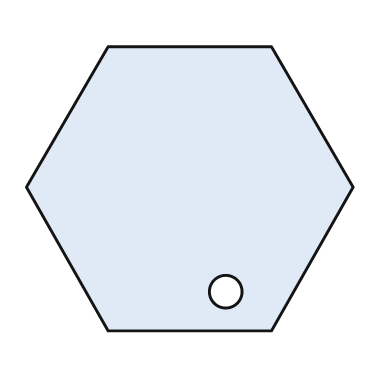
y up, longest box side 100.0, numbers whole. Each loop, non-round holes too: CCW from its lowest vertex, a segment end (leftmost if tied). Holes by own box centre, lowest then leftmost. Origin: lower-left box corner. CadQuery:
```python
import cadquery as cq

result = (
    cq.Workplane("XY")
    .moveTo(25.0, 0.0)
    .lineTo(75.0, 0.0)
    .lineTo(100.0, 44.0)
    .lineTo(75.0, 87.0)
    .lineTo(25.0, 87.0)
    .lineTo(0.0, 44.0)
    .close()
    .moveTo(61.0, 12.0)
    .circle(5.0)
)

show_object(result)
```